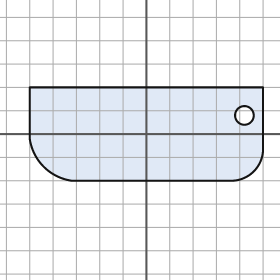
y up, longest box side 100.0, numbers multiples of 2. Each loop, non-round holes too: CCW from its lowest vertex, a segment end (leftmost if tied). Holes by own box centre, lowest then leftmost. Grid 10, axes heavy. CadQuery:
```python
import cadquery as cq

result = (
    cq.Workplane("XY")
    .moveTo(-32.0, -20.0)
    .lineTo(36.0, -20.0)
    .threePointArc((46.0, -16.0), (50.0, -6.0))
    .lineTo(50.0, 20.0)
    .lineTo(-50.0, 20.0)
    .lineTo(-50.0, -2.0)
    .threePointArc((-44.0, -14.0), (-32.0, -20.0))
    .close()
    .moveTo(42.0, 8.0)
    .circle(4.0)
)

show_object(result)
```